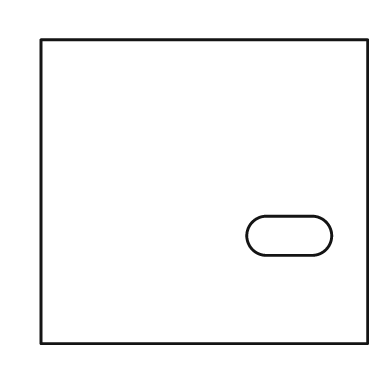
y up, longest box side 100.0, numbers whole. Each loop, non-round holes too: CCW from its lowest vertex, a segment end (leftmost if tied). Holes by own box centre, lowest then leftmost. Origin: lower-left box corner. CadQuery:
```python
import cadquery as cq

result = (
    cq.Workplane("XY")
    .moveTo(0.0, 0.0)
    .lineTo(100.0, 0.0)
    .lineTo(100.0, 93.0)
    .lineTo(0.0, 93.0)
    .close()
    .moveTo(69.0, 27.0)
    .lineTo(83.0, 27.0)
    .threePointArc((89.0, 33.0), (83.0, 39.0))
    .lineTo(69.0, 39.0)
    .threePointArc((63.0, 33.0), (69.0, 27.0))
    .close()
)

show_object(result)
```